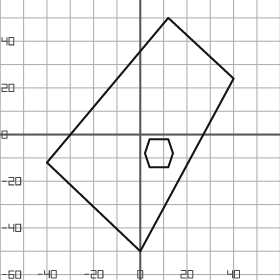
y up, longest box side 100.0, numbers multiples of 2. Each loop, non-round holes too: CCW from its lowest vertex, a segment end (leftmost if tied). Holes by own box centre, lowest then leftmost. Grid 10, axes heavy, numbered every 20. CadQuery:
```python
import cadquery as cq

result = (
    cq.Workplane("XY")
    .moveTo(0.0, -50.0)
    .lineTo(40.0, 24.0)
    .lineTo(12.0, 50.0)
    .lineTo(-40.0, -12.0)
    .close()
    .moveTo(4.0, -14.0)
    .lineTo(12.0, -14.0)
    .lineTo(14.0, -8.0)
    .lineTo(12.0, -2.0)
    .lineTo(4.0, -2.0)
    .lineTo(2.0, -8.0)
    .close()
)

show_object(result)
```